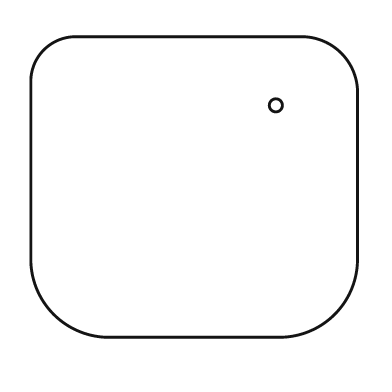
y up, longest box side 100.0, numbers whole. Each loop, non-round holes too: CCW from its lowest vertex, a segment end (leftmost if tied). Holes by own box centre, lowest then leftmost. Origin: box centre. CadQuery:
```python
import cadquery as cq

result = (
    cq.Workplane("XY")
    .moveTo(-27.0, -46.0)
    .lineTo(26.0, -46.0)
    .threePointArc((43.0, -39.0), (50.0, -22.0))
    .lineTo(50.0, 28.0)
    .threePointArc((45.0, 41.0), (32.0, 46.0))
    .lineTo(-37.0, 46.0)
    .threePointArc((-46.0, 42.0), (-50.0, 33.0))
    .lineTo(-50.0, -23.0)
    .threePointArc((-43.0, -39.0), (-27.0, -46.0))
    .close()
    .moveTo(25.0, 25.0)
    .circle(2.0)
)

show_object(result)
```